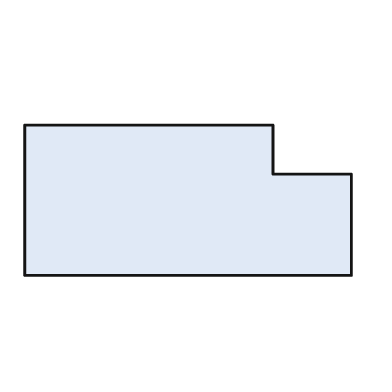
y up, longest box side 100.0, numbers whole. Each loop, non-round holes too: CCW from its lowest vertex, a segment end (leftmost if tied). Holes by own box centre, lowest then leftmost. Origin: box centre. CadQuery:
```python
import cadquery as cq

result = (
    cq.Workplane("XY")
    .moveTo(-50.0, -23.0)
    .lineTo(50.0, -23.0)
    .lineTo(50.0, 8.0)
    .lineTo(26.0, 8.0)
    .lineTo(26.0, 23.0)
    .lineTo(-50.0, 23.0)
    .close()
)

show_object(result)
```